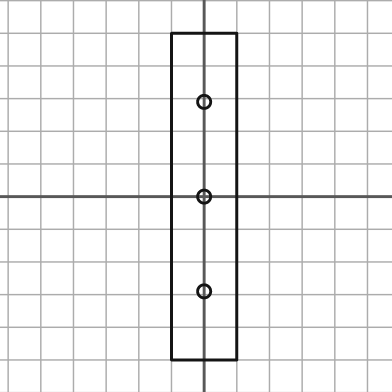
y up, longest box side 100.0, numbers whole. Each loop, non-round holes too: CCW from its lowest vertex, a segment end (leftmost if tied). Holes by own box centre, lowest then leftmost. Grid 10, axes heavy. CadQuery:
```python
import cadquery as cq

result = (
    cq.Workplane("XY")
    .moveTo(-10.0, -50.0)
    .lineTo(10.0, -50.0)
    .lineTo(10.0, 50.0)
    .lineTo(-10.0, 50.0)
    .close()
    .moveTo(0.0, -29.0)
    .circle(2.0)
    .moveTo(0.0, 0.0)
    .circle(2.0)
    .moveTo(0.0, 29.0)
    .circle(2.0)
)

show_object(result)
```